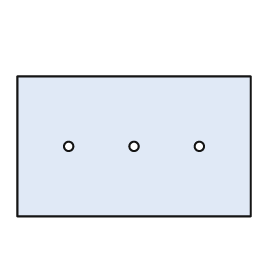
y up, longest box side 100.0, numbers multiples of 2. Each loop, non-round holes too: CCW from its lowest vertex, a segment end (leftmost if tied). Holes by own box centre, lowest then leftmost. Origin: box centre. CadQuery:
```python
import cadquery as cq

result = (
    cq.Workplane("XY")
    .moveTo(-50.0, -30.0)
    .lineTo(50.0, -30.0)
    .lineTo(50.0, 30.0)
    .lineTo(-50.0, 30.0)
    .close()
    .moveTo(-28.0, 0.0)
    .circle(2.0)
    .moveTo(0.0, 0.0)
    .circle(2.0)
    .moveTo(28.0, 0.0)
    .circle(2.0)
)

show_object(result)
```